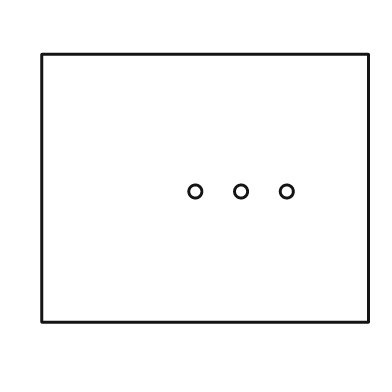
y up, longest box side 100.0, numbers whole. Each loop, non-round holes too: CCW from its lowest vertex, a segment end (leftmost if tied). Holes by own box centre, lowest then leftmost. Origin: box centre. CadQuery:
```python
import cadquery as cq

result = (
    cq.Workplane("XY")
    .moveTo(-50.0, -41.0)
    .lineTo(50.0, -41.0)
    .lineTo(50.0, 41.0)
    .lineTo(-50.0, 41.0)
    .close()
    .moveTo(-3.0, -1.0)
    .circle(2.0)
    .moveTo(11.0, -1.0)
    .circle(2.0)
    .moveTo(25.0, -1.0)
    .circle(2.0)
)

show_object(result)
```